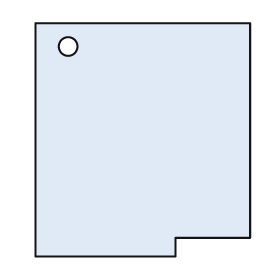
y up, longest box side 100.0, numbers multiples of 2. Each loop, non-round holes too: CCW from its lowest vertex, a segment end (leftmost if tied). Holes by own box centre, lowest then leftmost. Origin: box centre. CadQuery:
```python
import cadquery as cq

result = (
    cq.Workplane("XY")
    .moveTo(-46.0, -50.0)
    .lineTo(14.0, -50.0)
    .lineTo(14.0, -42.0)
    .lineTo(46.0, -42.0)
    .lineTo(46.0, 50.0)
    .lineTo(-46.0, 50.0)
    .close()
    .moveTo(-32.0, 40.0)
    .circle(4.0)
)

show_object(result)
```